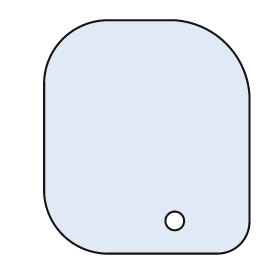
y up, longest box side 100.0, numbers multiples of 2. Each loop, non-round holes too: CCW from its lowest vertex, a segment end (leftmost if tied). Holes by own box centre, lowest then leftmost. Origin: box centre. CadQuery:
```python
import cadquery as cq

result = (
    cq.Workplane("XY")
    .moveTo(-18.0, -50.0)
    .lineTo(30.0, -50.0)
    .threePointArc((40.0, -46.0), (44.0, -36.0))
    .lineTo(44.0, 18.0)
    .threePointArc((34.0, 40.0), (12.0, 50.0))
    .lineTo(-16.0, 50.0)
    .threePointArc((-36.0, 42.0), (-44.0, 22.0))
    .lineTo(-44.0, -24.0)
    .threePointArc((-36.0, -42.0), (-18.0, -50.0))
    .close()
    .moveTo(12.0, -36.0)
    .circle(4.0)
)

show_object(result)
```